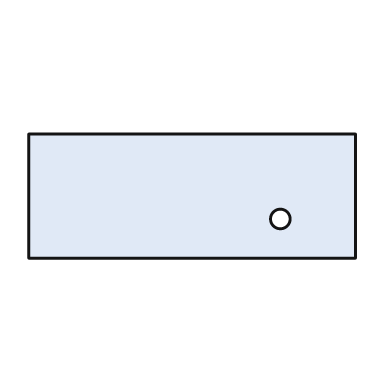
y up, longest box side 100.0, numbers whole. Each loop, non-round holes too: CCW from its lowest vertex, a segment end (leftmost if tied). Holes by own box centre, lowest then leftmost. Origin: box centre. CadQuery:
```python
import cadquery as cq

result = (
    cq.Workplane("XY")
    .moveTo(-50.0, -19.0)
    .lineTo(50.0, -19.0)
    .lineTo(50.0, 19.0)
    .lineTo(-50.0, 19.0)
    .close()
    .moveTo(27.0, -7.0)
    .circle(3.0)
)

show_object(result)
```